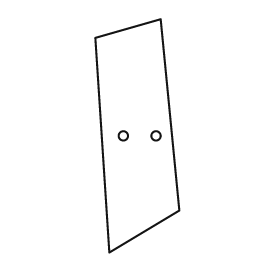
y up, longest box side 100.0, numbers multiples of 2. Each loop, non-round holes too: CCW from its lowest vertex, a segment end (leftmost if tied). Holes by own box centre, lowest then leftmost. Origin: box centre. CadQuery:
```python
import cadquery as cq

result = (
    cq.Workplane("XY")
    .moveTo(-12.0, -50.0)
    .lineTo(18.0, -32.0)
    .lineTo(10.0, 50.0)
    .lineTo(-18.0, 42.0)
    .close()
    .moveTo(-6.0, 0.0)
    .circle(2.0)
    .moveTo(8.0, 0.0)
    .circle(2.0)
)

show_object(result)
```